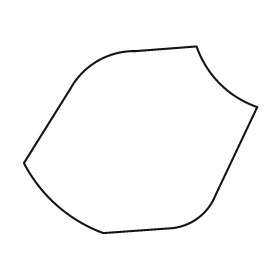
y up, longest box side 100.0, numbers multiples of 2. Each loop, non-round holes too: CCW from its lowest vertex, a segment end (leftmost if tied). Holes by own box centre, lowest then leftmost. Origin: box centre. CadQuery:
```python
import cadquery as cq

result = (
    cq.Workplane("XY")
    .moveTo(-16.0, -40.0)
    .lineTo(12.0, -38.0)
    .threePointArc((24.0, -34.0), (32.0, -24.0))
    .lineTo(50.0, 14.0)
    .threePointArc((34.0, 24.0), (24.0, 40.0))
    .lineTo(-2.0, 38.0)
    .threePointArc((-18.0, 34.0), (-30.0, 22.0))
    .lineTo(-50.0, -10.0)
    .threePointArc((-36.0, -28.0), (-16.0, -40.0))
    .close()
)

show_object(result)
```